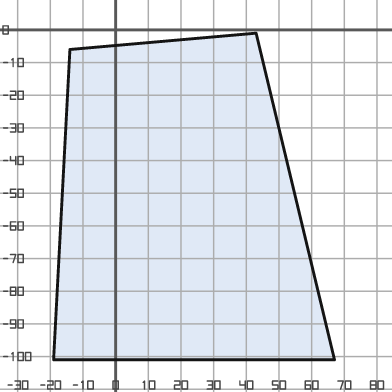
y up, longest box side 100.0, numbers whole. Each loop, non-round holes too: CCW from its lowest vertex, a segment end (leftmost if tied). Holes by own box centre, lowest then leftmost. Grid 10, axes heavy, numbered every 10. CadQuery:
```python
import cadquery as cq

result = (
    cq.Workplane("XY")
    .moveTo(-19.0, -101.0)
    .lineTo(67.0, -101.0)
    .lineTo(43.0, -1.0)
    .lineTo(-14.0, -6.0)
    .close()
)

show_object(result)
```